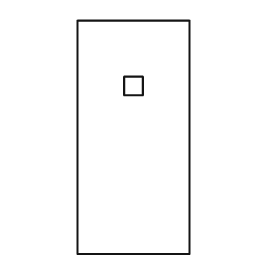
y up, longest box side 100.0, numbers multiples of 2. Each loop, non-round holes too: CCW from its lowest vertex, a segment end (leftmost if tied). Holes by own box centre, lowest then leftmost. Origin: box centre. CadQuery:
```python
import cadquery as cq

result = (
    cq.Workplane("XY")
    .moveTo(-24.0, -50.0)
    .lineTo(24.0, -50.0)
    .lineTo(24.0, 50.0)
    .lineTo(-24.0, 50.0)
    .close()
    .moveTo(-4.0, 18.0)
    .lineTo(4.0, 18.0)
    .lineTo(4.0, 26.0)
    .lineTo(-4.0, 26.0)
    .close()
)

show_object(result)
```